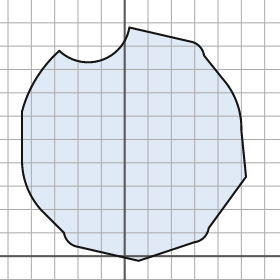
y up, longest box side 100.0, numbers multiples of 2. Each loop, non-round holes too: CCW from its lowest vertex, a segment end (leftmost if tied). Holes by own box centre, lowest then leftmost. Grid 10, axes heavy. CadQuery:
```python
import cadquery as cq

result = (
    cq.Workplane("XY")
    .moveTo(6.0, -2.0)
    .lineTo(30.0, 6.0)
    .threePointArc((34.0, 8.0), (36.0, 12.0))
    .lineTo(52.0, 34.0)
    .lineTo(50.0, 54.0)
    .threePointArc((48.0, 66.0), (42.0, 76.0))
    .lineTo(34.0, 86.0)
    .threePointArc((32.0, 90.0), (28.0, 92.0))
    .lineTo(2.0, 98.0)
    .threePointArc((-10.0, 84.0), (-28.0, 88.0))
    .threePointArc((-38.0, 76.0), (-44.0, 62.0))
    .lineTo(-44.0, 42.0)
    .threePointArc((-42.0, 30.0), (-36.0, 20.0))
    .lineTo(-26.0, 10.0)
    .threePointArc((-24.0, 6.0), (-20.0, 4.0))
    .close()
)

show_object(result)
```